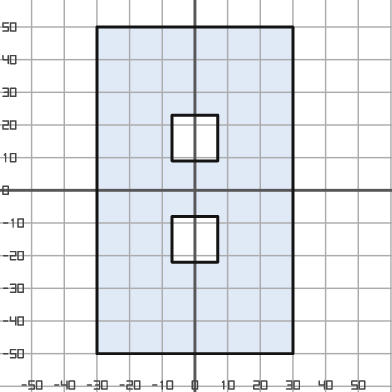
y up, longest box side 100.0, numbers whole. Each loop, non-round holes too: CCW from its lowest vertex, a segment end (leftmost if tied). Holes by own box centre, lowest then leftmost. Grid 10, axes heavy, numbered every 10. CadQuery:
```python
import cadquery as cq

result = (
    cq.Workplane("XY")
    .moveTo(-30.0, -50.0)
    .lineTo(30.0, -50.0)
    .lineTo(30.0, 50.0)
    .lineTo(-30.0, 50.0)
    .close()
    .moveTo(-7.0, -22.0)
    .lineTo(7.0, -22.0)
    .lineTo(7.0, -8.0)
    .lineTo(-7.0, -8.0)
    .close()
    .moveTo(-7.0, 9.0)
    .lineTo(7.0, 9.0)
    .lineTo(7.0, 23.0)
    .lineTo(-7.0, 23.0)
    .close()
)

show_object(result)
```